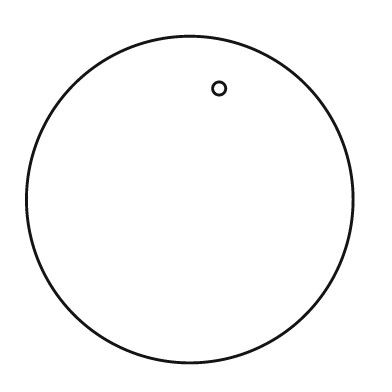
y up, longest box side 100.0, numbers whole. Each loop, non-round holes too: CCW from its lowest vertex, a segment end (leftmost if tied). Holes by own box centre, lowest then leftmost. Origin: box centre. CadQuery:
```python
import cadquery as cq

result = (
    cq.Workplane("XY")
    .moveTo(0.0, 0.0)
    .circle(50.0)
    .moveTo(9.0, 34.0)
    .circle(2.0)
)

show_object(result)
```